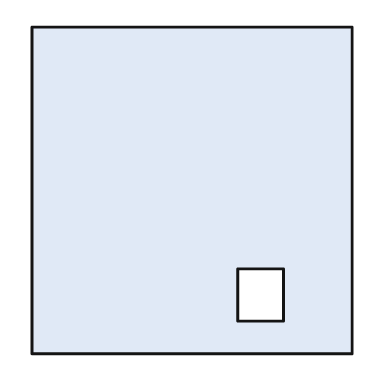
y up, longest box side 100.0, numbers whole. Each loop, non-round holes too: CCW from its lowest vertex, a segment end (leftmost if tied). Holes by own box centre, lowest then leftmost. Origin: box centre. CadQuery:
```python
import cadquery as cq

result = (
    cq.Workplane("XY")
    .moveTo(-49.0, -50.0)
    .lineTo(49.0, -50.0)
    .lineTo(49.0, 50.0)
    .lineTo(-49.0, 50.0)
    .close()
    .moveTo(14.0, -40.0)
    .lineTo(28.0, -40.0)
    .lineTo(28.0, -24.0)
    .lineTo(14.0, -24.0)
    .close()
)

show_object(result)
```